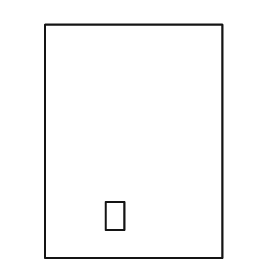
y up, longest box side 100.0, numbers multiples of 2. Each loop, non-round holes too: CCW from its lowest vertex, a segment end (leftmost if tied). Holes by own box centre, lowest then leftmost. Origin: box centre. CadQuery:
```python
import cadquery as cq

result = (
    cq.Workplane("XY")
    .moveTo(-38.0, -50.0)
    .lineTo(38.0, -50.0)
    .lineTo(38.0, 50.0)
    .lineTo(-38.0, 50.0)
    .close()
    .moveTo(-12.0, -38.0)
    .lineTo(-4.0, -38.0)
    .lineTo(-4.0, -26.0)
    .lineTo(-12.0, -26.0)
    .close()
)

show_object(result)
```